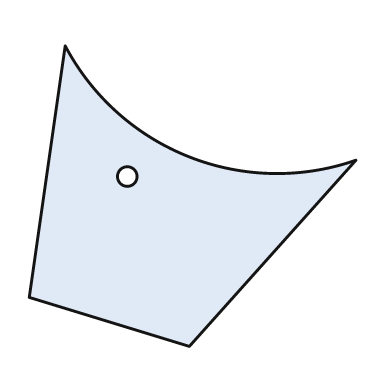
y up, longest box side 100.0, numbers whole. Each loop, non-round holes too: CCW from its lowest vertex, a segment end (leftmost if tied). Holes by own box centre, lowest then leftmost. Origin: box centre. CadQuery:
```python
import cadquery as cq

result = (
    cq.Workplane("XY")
    .moveTo(-1.0, -46.0)
    .lineTo(50.0, 11.0)
    .threePointArc((-1.0, 12.0), (-39.0, 46.0))
    .lineTo(-50.0, -31.0)
    .close()
    .moveTo(-20.0, 6.0)
    .circle(3.0)
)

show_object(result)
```